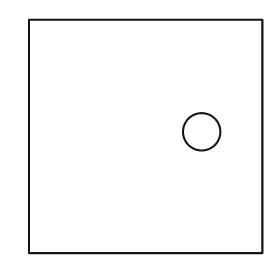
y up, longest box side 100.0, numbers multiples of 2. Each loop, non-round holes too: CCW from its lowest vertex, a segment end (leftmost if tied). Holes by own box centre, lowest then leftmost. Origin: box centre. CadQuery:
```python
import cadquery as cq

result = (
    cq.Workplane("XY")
    .moveTo(-50.0, -50.0)
    .lineTo(50.0, -50.0)
    .lineTo(50.0, 50.0)
    .lineTo(-50.0, 50.0)
    .close()
    .moveTo(24.0, 2.0)
    .circle(8.0)
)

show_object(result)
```